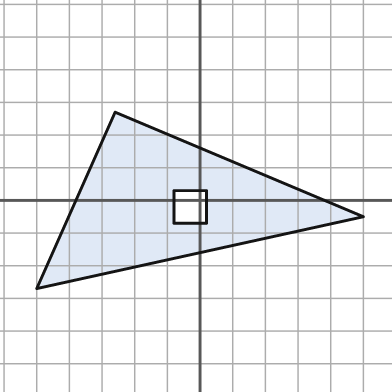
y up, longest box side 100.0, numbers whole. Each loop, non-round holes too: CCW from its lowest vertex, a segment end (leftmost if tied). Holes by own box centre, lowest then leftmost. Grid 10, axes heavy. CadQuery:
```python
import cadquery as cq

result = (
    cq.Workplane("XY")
    .moveTo(-50.0, -27.0)
    .lineTo(50.0, -5.0)
    .lineTo(-26.0, 27.0)
    .close()
    .moveTo(-8.0, -7.0)
    .lineTo(2.0, -7.0)
    .lineTo(2.0, 3.0)
    .lineTo(-8.0, 3.0)
    .close()
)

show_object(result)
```